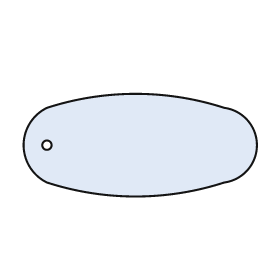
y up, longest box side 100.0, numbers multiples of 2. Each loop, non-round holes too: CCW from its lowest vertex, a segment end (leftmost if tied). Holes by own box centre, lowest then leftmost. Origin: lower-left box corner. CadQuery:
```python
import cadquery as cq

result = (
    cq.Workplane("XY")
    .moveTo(10.0, 6.0)
    .threePointArc((48.0, 0.0), (86.0, 6.0))
    .threePointArc((100.0, 22.0), (86.0, 38.0))
    .threePointArc((48.0, 44.0), (10.0, 38.0))
    .threePointArc((0.0, 22.0), (10.0, 6.0))
    .close()
    .moveTo(10.0, 22.0)
    .circle(2.0)
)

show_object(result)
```